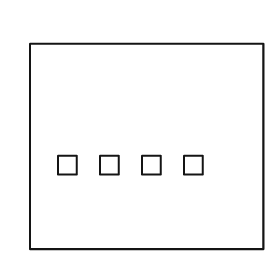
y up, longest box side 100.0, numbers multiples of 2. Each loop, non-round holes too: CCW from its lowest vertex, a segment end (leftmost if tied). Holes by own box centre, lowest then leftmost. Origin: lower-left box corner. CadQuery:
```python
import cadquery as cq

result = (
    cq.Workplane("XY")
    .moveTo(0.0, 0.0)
    .lineTo(100.0, 0.0)
    .lineTo(100.0, 88.0)
    .lineTo(0.0, 88.0)
    .close()
    .moveTo(12.0, 32.0)
    .lineTo(20.0, 32.0)
    .lineTo(20.0, 40.0)
    .lineTo(12.0, 40.0)
    .close()
    .moveTo(30.0, 32.0)
    .lineTo(38.0, 32.0)
    .lineTo(38.0, 40.0)
    .lineTo(30.0, 40.0)
    .close()
    .moveTo(48.0, 32.0)
    .lineTo(56.0, 32.0)
    .lineTo(56.0, 40.0)
    .lineTo(48.0, 40.0)
    .close()
    .moveTo(66.0, 32.0)
    .lineTo(74.0, 32.0)
    .lineTo(74.0, 40.0)
    .lineTo(66.0, 40.0)
    .close()
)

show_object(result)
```